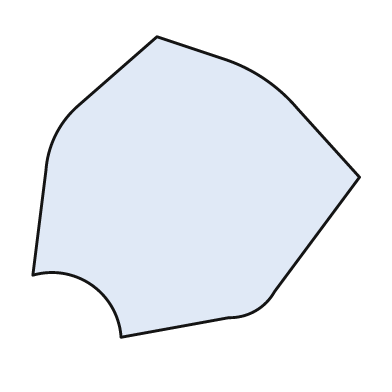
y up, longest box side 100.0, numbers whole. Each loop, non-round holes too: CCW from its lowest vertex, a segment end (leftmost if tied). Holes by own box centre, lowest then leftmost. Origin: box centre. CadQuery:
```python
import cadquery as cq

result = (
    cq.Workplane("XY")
    .moveTo(-23.0, -46.0)
    .lineTo(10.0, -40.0)
    .threePointArc((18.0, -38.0), (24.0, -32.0))
    .lineTo(50.0, 3.0)
    .lineTo(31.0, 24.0)
    .threePointArc((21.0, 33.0), (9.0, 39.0))
    .lineTo(-12.0, 46.0)
    .lineTo(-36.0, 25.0)
    .threePointArc((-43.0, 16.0), (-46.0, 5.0))
    .lineTo(-50.0, -27.0)
    .threePointArc((-32.0, -30.0), (-23.0, -46.0))
    .close()
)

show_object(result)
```